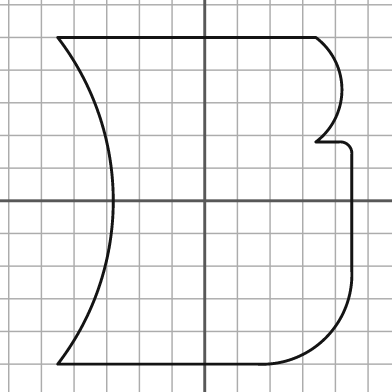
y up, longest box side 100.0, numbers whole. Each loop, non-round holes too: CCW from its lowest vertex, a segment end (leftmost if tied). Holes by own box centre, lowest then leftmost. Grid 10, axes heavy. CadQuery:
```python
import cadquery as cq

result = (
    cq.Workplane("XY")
    .moveTo(-45.0, -50.0)
    .lineTo(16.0, -50.0)
    .threePointArc((37.0, -42.0), (45.0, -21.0))
    .lineTo(45.0, 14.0)
    .threePointArc((44.0, 17.0), (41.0, 18.0))
    .lineTo(34.0, 18.0)
    .threePointArc((42.0, 34.0), (34.0, 50.0))
    .lineTo(-45.0, 50.0)
    .threePointArc((-28.0, 0.0), (-45.0, -50.0))
    .close()
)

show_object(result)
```